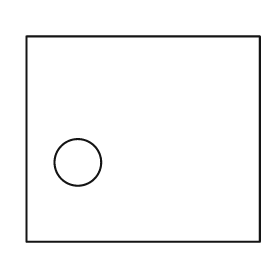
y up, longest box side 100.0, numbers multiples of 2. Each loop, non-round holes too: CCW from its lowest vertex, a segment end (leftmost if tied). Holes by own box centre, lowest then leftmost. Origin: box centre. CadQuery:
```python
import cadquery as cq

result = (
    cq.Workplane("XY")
    .moveTo(-50.0, -44.0)
    .lineTo(50.0, -44.0)
    .lineTo(50.0, 44.0)
    .lineTo(-50.0, 44.0)
    .close()
    .moveTo(-28.0, -10.0)
    .circle(10.0)
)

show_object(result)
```